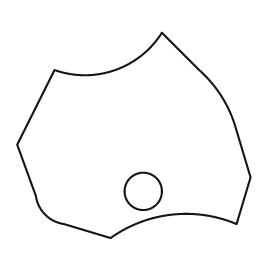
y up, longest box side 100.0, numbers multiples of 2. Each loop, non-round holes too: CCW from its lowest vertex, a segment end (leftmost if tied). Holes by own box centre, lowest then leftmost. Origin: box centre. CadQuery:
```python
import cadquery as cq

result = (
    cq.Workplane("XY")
    .moveTo(-10.0, -44.0)
    .threePointArc((16.0, -34.0), (44.0, -38.0))
    .lineTo(50.0, -18.0)
    .lineTo(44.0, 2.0)
    .threePointArc((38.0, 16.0), (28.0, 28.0))
    .lineTo(12.0, 44.0)
    .threePointArc((-8.0, 28.0), (-34.0, 28.0))
    .lineTo(-50.0, -4.0)
    .lineTo(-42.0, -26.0)
    .threePointArc((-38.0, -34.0), (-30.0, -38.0))
    .close()
    .moveTo(4.0, -24.0)
    .circle(8.0)
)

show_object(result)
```